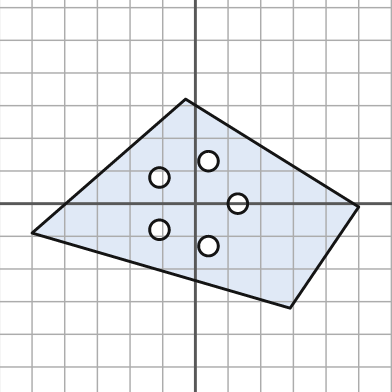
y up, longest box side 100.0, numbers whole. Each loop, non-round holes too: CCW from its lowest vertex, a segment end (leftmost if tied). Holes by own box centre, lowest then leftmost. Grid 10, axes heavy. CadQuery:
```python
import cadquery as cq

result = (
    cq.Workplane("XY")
    .moveTo(29.0, -32.0)
    .lineTo(50.0, -1.0)
    .lineTo(-3.0, 32.0)
    .lineTo(-50.0, -9.0)
    .close()
    .moveTo(4.0, -13.0)
    .circle(3.0)
    .moveTo(-11.0, -8.0)
    .circle(3.0)
    .moveTo(13.0, 0.0)
    .circle(3.0)
    .moveTo(-11.0, 8.0)
    .circle(3.0)
    .moveTo(4.0, 13.0)
    .circle(3.0)
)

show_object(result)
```